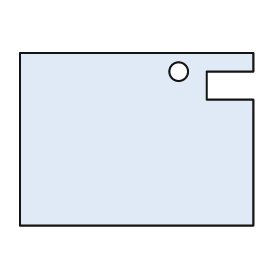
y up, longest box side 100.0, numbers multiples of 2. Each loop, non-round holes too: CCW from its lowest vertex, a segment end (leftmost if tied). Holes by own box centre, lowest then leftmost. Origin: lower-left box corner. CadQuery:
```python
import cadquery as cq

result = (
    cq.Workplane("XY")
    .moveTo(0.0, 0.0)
    .lineTo(100.0, 0.0)
    .lineTo(100.0, 54.0)
    .lineTo(80.0, 54.0)
    .lineTo(80.0, 66.0)
    .lineTo(100.0, 66.0)
    .lineTo(100.0, 74.0)
    .lineTo(0.0, 74.0)
    .close()
    .moveTo(68.0, 66.0)
    .circle(4.0)
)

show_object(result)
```